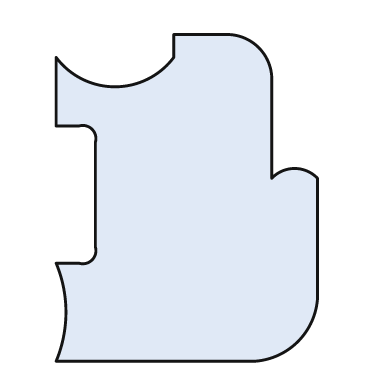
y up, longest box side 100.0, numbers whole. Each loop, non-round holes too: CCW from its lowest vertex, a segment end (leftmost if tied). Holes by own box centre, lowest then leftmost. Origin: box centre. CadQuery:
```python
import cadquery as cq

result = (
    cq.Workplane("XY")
    .moveTo(-40.0, -50.0)
    .lineTo(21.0, -50.0)
    .threePointArc((34.0, -44.0), (40.0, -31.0))
    .lineTo(40.0, 6.0)
    .threePointArc((33.0, 9.0), (26.0, 6.0))
    .lineTo(26.0, 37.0)
    .threePointArc((22.0, 46.0), (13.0, 50.0))
    .lineTo(-4.0, 50.0)
    .lineTo(-4.0, 43.0)
    .threePointArc((-22.0, 34.0), (-40.0, 43.0))
    .lineTo(-40.0, 22.0)
    .lineTo(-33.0, 22.0)
    .threePointArc((-29.0, 21.0), (-28.0, 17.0))
    .lineTo(-28.0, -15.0)
    .threePointArc((-29.0, -19.0), (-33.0, -20.0))
    .lineTo(-40.0, -20.0)
    .threePointArc((-37.0, -35.0), (-40.0, -50.0))
    .close()
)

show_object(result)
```